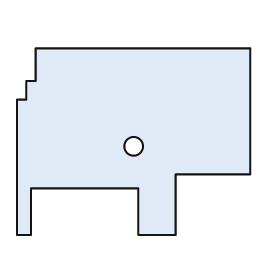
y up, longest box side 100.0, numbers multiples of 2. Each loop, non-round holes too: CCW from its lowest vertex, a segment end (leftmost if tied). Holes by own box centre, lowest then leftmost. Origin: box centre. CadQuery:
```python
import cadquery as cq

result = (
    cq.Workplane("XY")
    .moveTo(-50.0, -40.0)
    .lineTo(-44.0, -40.0)
    .lineTo(-44.0, -20.0)
    .lineTo(2.0, -20.0)
    .lineTo(2.0, -40.0)
    .lineTo(18.0, -40.0)
    .lineTo(18.0, -14.0)
    .lineTo(50.0, -14.0)
    .lineTo(50.0, 40.0)
    .lineTo(-42.0, 40.0)
    .lineTo(-42.0, 26.0)
    .lineTo(-46.0, 26.0)
    .lineTo(-46.0, 18.0)
    .lineTo(-50.0, 18.0)
    .close()
    .moveTo(0.0, -2.0)
    .circle(4.0)
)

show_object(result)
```